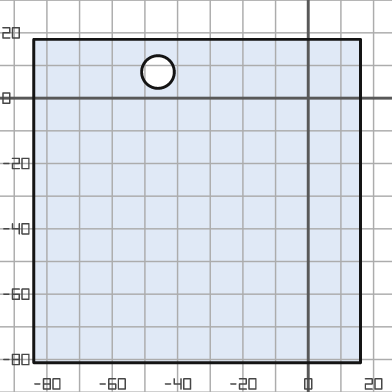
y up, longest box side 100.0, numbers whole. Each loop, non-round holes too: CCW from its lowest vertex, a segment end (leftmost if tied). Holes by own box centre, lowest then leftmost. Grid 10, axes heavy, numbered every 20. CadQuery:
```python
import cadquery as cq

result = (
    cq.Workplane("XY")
    .moveTo(-84.0, -81.0)
    .lineTo(16.0, -81.0)
    .lineTo(16.0, 18.0)
    .lineTo(-84.0, 18.0)
    .close()
    .moveTo(-46.0, 8.0)
    .circle(5.0)
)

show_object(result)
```